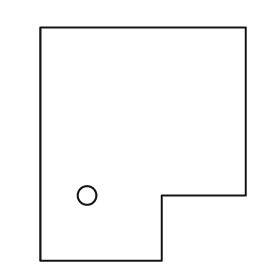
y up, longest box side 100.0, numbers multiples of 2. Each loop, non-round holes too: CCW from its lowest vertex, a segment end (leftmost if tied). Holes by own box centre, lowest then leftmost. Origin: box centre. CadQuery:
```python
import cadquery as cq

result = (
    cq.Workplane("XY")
    .moveTo(-44.0, -50.0)
    .lineTo(8.0, -50.0)
    .lineTo(8.0, -22.0)
    .lineTo(44.0, -22.0)
    .lineTo(44.0, 50.0)
    .lineTo(-44.0, 50.0)
    .close()
    .moveTo(-24.0, -22.0)
    .circle(4.0)
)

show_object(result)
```